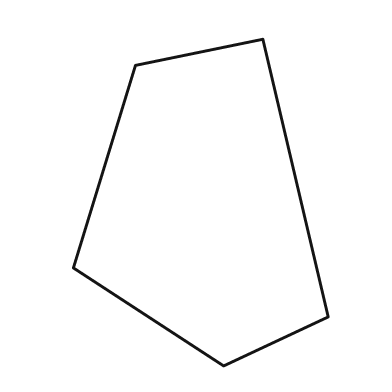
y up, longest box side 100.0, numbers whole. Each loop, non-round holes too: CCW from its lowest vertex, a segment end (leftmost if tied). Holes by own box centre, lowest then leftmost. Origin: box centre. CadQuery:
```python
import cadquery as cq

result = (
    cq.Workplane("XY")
    .moveTo(7.0, -50.0)
    .lineTo(39.0, -35.0)
    .lineTo(19.0, 50.0)
    .lineTo(-20.0, 42.0)
    .lineTo(-39.0, -20.0)
    .close()
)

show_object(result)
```